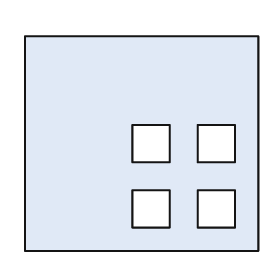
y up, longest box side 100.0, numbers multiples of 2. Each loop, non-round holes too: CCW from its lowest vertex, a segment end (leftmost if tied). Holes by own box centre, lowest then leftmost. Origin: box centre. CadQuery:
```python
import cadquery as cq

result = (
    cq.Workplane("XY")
    .moveTo(-50.0, -46.0)
    .lineTo(50.0, -46.0)
    .lineTo(50.0, 46.0)
    .lineTo(-50.0, 46.0)
    .close()
    .moveTo(-4.0, -36.0)
    .lineTo(12.0, -36.0)
    .lineTo(12.0, -20.0)
    .lineTo(-4.0, -20.0)
    .close()
    .moveTo(24.0, -36.0)
    .lineTo(40.0, -36.0)
    .lineTo(40.0, -20.0)
    .lineTo(24.0, -20.0)
    .close()
    .moveTo(-4.0, -8.0)
    .lineTo(12.0, -8.0)
    .lineTo(12.0, 8.0)
    .lineTo(-4.0, 8.0)
    .close()
    .moveTo(24.0, -8.0)
    .lineTo(40.0, -8.0)
    .lineTo(40.0, 8.0)
    .lineTo(24.0, 8.0)
    .close()
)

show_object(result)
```